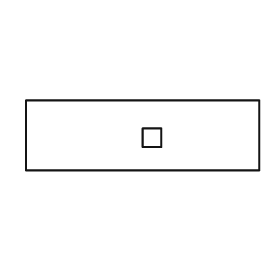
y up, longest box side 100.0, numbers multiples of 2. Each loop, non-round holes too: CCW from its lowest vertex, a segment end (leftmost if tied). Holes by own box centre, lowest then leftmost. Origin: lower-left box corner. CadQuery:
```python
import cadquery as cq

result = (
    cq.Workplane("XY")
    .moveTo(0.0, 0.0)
    .lineTo(100.0, 0.0)
    .lineTo(100.0, 30.0)
    .lineTo(0.0, 30.0)
    .close()
    .moveTo(50.0, 10.0)
    .lineTo(58.0, 10.0)
    .lineTo(58.0, 18.0)
    .lineTo(50.0, 18.0)
    .close()
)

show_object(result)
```